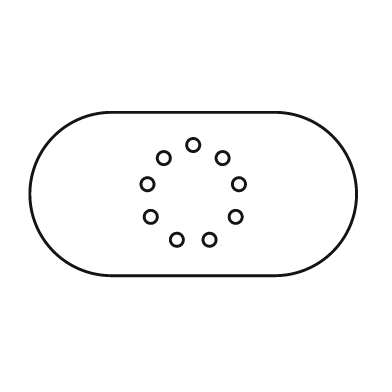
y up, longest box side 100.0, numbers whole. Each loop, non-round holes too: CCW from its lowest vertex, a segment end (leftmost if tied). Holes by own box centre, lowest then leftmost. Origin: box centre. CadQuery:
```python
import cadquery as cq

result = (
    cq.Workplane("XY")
    .moveTo(-25.0, -25.0)
    .lineTo(25.0, -25.0)
    .threePointArc((50.0, 0.0), (25.0, 25.0))
    .lineTo(-25.0, 25.0)
    .threePointArc((-50.0, 0.0), (-25.0, -25.0))
    .close()
    .moveTo(-5.0, -14.0)
    .circle(2.0)
    .moveTo(5.0, -14.0)
    .circle(2.0)
    .moveTo(-13.0, -7.0)
    .circle(2.0)
    .moveTo(13.0, -7.0)
    .circle(2.0)
    .moveTo(-14.0, 3.0)
    .circle(2.0)
    .moveTo(14.0, 3.0)
    .circle(2.0)
    .moveTo(-9.0, 11.0)
    .circle(2.0)
    .moveTo(9.0, 11.0)
    .circle(2.0)
    .moveTo(0.0, 15.0)
    .circle(2.0)
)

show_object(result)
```